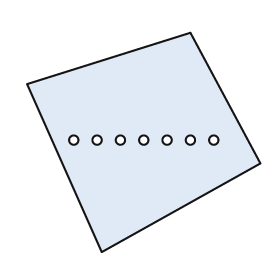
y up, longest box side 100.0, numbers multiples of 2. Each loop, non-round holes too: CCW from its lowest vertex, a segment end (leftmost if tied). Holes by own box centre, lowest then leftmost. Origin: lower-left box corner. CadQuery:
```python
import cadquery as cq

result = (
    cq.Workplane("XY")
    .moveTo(32.0, 0.0)
    .lineTo(100.0, 38.0)
    .lineTo(70.0, 94.0)
    .lineTo(0.0, 72.0)
    .close()
    .moveTo(20.0, 48.0)
    .circle(2.0)
    .moveTo(30.0, 48.0)
    .circle(2.0)
    .moveTo(40.0, 48.0)
    .circle(2.0)
    .moveTo(50.0, 48.0)
    .circle(2.0)
    .moveTo(60.0, 48.0)
    .circle(2.0)
    .moveTo(70.0, 48.0)
    .circle(2.0)
    .moveTo(80.0, 48.0)
    .circle(2.0)
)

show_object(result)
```